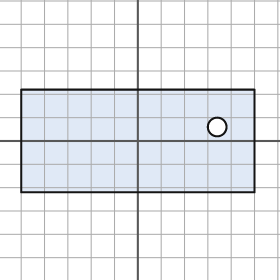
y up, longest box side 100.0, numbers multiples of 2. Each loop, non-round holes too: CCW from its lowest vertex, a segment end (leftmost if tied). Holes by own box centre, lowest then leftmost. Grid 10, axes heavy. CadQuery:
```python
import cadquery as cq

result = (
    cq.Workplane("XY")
    .moveTo(-50.0, -22.0)
    .lineTo(50.0, -22.0)
    .lineTo(50.0, 22.0)
    .lineTo(-50.0, 22.0)
    .close()
    .moveTo(34.0, 6.0)
    .circle(4.0)
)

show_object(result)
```